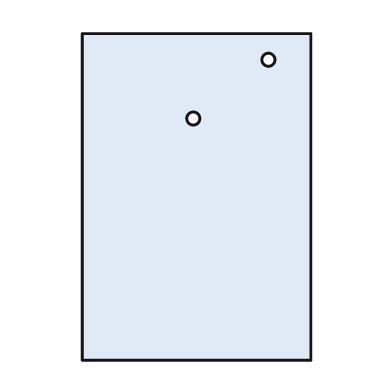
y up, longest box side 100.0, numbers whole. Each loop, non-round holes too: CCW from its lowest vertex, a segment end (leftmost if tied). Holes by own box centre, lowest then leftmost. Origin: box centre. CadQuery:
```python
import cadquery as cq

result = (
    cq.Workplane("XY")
    .moveTo(-35.0, -50.0)
    .lineTo(35.0, -50.0)
    .lineTo(35.0, 50.0)
    .lineTo(-35.0, 50.0)
    .close()
    .moveTo(-1.0, 24.0)
    .circle(2.0)
    .moveTo(22.0, 42.0)
    .circle(2.0)
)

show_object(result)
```